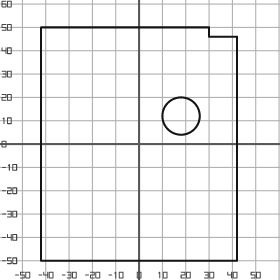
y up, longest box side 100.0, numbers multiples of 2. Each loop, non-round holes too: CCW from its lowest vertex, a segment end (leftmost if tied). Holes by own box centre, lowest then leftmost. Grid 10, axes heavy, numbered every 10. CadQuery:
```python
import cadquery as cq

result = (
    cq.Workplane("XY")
    .moveTo(-42.0, -50.0)
    .lineTo(42.0, -50.0)
    .lineTo(42.0, 46.0)
    .lineTo(30.0, 46.0)
    .lineTo(30.0, 50.0)
    .lineTo(-42.0, 50.0)
    .close()
    .moveTo(18.0, 12.0)
    .circle(8.0)
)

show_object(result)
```